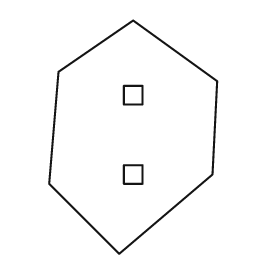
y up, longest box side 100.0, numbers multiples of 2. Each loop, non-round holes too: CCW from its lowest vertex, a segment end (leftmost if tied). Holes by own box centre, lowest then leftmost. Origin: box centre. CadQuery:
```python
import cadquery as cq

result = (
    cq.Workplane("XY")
    .moveTo(-6.0, -50.0)
    .lineTo(34.0, -16.0)
    .lineTo(36.0, 24.0)
    .lineTo(0.0, 50.0)
    .lineTo(-32.0, 28.0)
    .lineTo(-36.0, -20.0)
    .close()
    .moveTo(-4.0, -20.0)
    .lineTo(4.0, -20.0)
    .lineTo(4.0, -12.0)
    .lineTo(-4.0, -12.0)
    .close()
    .moveTo(-4.0, 14.0)
    .lineTo(4.0, 14.0)
    .lineTo(4.0, 22.0)
    .lineTo(-4.0, 22.0)
    .close()
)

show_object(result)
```